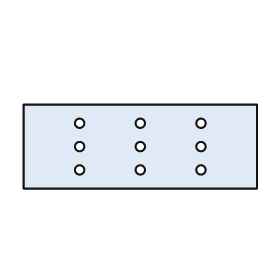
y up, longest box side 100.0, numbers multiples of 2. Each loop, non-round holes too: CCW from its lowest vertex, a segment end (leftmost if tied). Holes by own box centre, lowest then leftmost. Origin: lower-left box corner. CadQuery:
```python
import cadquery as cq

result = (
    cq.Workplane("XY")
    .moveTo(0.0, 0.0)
    .lineTo(100.0, 0.0)
    .lineTo(100.0, 36.0)
    .lineTo(0.0, 36.0)
    .close()
    .moveTo(24.0, 8.0)
    .circle(2.0)
    .moveTo(50.0, 8.0)
    .circle(2.0)
    .moveTo(76.0, 8.0)
    .circle(2.0)
    .moveTo(24.0, 18.0)
    .circle(2.0)
    .moveTo(50.0, 18.0)
    .circle(2.0)
    .moveTo(76.0, 18.0)
    .circle(2.0)
    .moveTo(24.0, 28.0)
    .circle(2.0)
    .moveTo(50.0, 28.0)
    .circle(2.0)
    .moveTo(76.0, 28.0)
    .circle(2.0)
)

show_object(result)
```